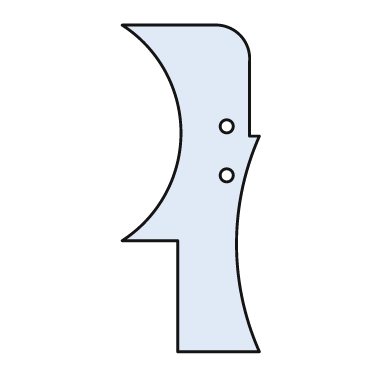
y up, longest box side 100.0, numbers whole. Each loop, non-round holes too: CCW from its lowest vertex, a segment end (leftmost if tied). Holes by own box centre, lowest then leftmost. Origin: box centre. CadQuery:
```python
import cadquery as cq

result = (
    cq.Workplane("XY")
    .moveTo(-4.0, -50.0)
    .lineTo(21.0, -50.0)
    .threePointArc((14.0, -17.0), (21.0, 16.0))
    .lineTo(18.0, 16.0)
    .lineTo(18.0, 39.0)
    .threePointArc((15.0, 47.0), (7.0, 50.0))
    .lineTo(-21.0, 50.0)
    .threePointArc((-3.0, 17.0), (-21.0, -16.0))
    .lineTo(-4.0, -16.0)
    .close()
    .moveTo(11.0, 4.0)
    .circle(2.0)
    .moveTo(11.0, 19.0)
    .circle(2.0)
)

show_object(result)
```